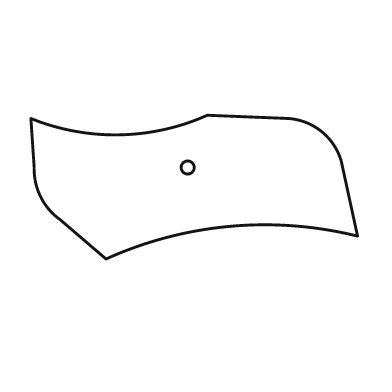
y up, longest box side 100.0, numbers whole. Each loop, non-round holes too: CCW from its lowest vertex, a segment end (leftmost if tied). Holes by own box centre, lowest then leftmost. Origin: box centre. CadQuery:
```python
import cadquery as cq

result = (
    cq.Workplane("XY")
    .moveTo(-27.0, -22.0)
    .threePointArc((11.0, -12.0), (50.0, -15.0))
    .lineTo(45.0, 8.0)
    .threePointArc((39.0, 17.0), (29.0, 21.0))
    .lineTo(4.0, 22.0)
    .threePointArc((-23.0, 16.0), (-50.0, 21.0))
    .lineTo(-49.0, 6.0)
    .threePointArc((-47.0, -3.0), (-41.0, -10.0))
    .close()
    .moveTo(-2.0, 6.0)
    .circle(2.0)
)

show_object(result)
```